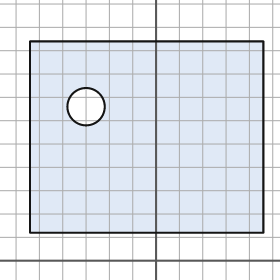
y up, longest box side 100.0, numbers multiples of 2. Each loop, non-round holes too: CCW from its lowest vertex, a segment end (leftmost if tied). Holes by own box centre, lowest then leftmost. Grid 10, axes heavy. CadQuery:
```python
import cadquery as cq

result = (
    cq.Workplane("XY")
    .moveTo(-54.0, 12.0)
    .lineTo(46.0, 12.0)
    .lineTo(46.0, 94.0)
    .lineTo(-54.0, 94.0)
    .close()
    .moveTo(-30.0, 66.0)
    .circle(8.0)
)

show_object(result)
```